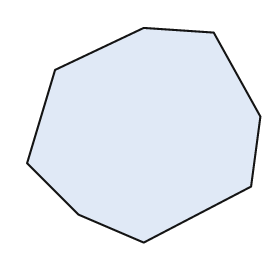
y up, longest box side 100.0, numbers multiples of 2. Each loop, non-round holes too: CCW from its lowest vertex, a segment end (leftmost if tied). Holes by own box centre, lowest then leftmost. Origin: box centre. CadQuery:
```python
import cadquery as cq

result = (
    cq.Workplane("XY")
    .moveTo(0.0, -46.0)
    .lineTo(46.0, -22.0)
    .lineTo(50.0, 8.0)
    .lineTo(30.0, 44.0)
    .lineTo(0.0, 46.0)
    .lineTo(-38.0, 28.0)
    .lineTo(-50.0, -12.0)
    .lineTo(-28.0, -34.0)
    .close()
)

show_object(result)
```